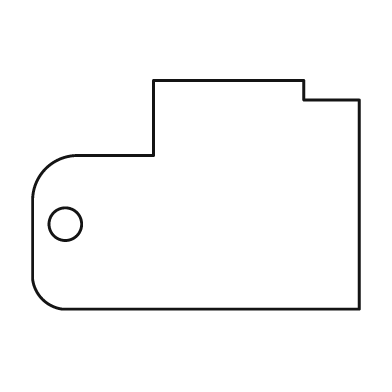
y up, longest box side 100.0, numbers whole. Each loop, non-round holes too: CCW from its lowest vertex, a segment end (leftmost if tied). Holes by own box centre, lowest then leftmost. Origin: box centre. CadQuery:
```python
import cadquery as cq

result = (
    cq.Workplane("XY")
    .moveTo(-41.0, -35.0)
    .lineTo(50.0, -35.0)
    .lineTo(50.0, 29.0)
    .lineTo(33.0, 29.0)
    .lineTo(33.0, 35.0)
    .lineTo(-13.0, 35.0)
    .lineTo(-13.0, 12.0)
    .lineTo(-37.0, 12.0)
    .threePointArc((-46.0, 8.0), (-50.0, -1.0))
    .lineTo(-50.0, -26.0)
    .threePointArc((-47.0, -32.0), (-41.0, -35.0))
    .close()
    .moveTo(-40.0, -9.0)
    .circle(5.0)
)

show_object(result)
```